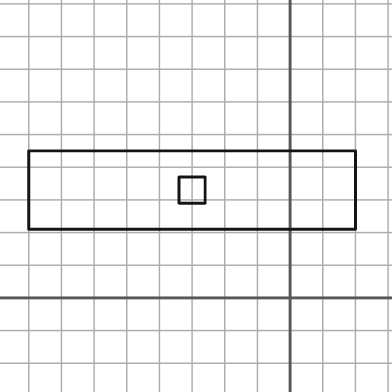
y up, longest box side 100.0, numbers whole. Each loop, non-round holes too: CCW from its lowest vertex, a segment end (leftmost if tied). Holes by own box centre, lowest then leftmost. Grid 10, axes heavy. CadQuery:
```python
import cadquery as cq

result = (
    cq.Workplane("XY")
    .moveTo(-80.0, 21.0)
    .lineTo(20.0, 21.0)
    .lineTo(20.0, 45.0)
    .lineTo(-80.0, 45.0)
    .close()
    .moveTo(-34.0, 29.0)
    .lineTo(-26.0, 29.0)
    .lineTo(-26.0, 37.0)
    .lineTo(-34.0, 37.0)
    .close()
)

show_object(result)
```